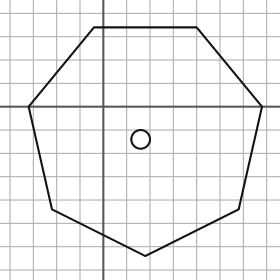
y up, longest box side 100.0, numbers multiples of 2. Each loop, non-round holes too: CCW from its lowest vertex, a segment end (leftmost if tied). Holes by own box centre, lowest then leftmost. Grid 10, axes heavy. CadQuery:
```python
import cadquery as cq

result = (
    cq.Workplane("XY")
    .moveTo(18.0, -64.0)
    .lineTo(58.0, -44.0)
    .lineTo(68.0, 0.0)
    .lineTo(40.0, 34.0)
    .lineTo(-4.0, 34.0)
    .lineTo(-32.0, 0.0)
    .lineTo(-22.0, -44.0)
    .close()
    .moveTo(16.0, -14.0)
    .circle(4.0)
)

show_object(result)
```